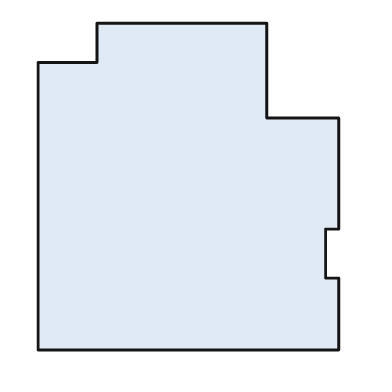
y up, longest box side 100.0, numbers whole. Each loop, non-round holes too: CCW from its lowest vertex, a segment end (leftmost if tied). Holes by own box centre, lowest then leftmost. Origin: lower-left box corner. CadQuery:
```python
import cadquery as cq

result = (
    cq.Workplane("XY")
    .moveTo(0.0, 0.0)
    .lineTo(92.0, 0.0)
    .lineTo(92.0, 22.0)
    .lineTo(88.0, 22.0)
    .lineTo(88.0, 37.0)
    .lineTo(92.0, 37.0)
    .lineTo(92.0, 71.0)
    .lineTo(70.0, 71.0)
    .lineTo(70.0, 100.0)
    .lineTo(18.0, 100.0)
    .lineTo(18.0, 88.0)
    .lineTo(0.0, 88.0)
    .close()
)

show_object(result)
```